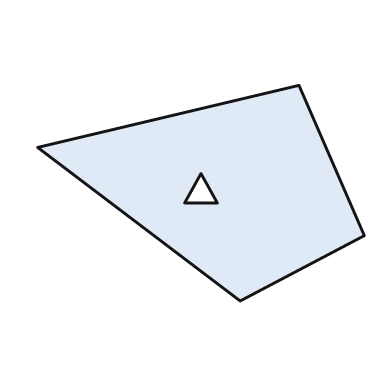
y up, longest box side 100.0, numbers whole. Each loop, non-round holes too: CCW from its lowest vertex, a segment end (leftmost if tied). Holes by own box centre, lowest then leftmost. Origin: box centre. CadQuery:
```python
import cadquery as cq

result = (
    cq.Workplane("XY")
    .moveTo(12.0, -33.0)
    .lineTo(50.0, -13.0)
    .lineTo(30.0, 33.0)
    .lineTo(-50.0, 14.0)
    .close()
    .moveTo(-5.0, -3.0)
    .lineTo(5.0, -3.0)
    .lineTo(0.0, 6.0)
    .close()
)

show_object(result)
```